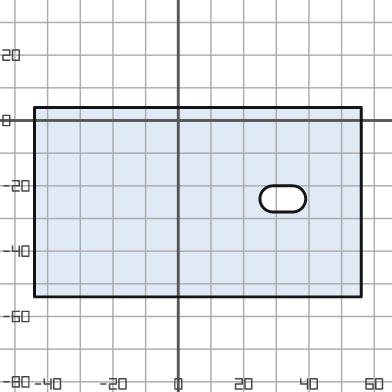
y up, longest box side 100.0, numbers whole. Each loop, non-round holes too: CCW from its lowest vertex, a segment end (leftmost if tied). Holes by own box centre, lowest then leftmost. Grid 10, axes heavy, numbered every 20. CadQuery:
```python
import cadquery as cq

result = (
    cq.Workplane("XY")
    .moveTo(-44.0, -54.0)
    .lineTo(56.0, -54.0)
    .lineTo(56.0, 4.0)
    .lineTo(-44.0, 4.0)
    .close()
    .moveTo(29.0, -28.0)
    .lineTo(35.0, -28.0)
    .threePointArc((39.0, -24.0), (35.0, -20.0))
    .lineTo(29.0, -20.0)
    .threePointArc((25.0, -24.0), (29.0, -28.0))
    .close()
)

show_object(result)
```